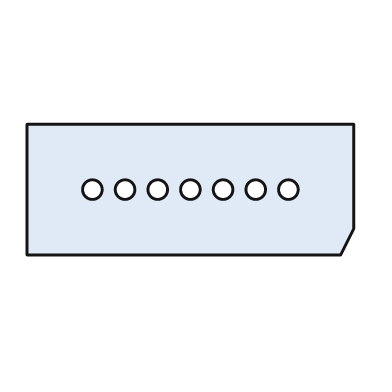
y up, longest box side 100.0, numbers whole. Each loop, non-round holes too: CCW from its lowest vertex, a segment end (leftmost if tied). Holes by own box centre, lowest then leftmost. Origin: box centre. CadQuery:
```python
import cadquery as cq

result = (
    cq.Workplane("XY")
    .moveTo(-50.0, -20.0)
    .lineTo(46.0, -20.0)
    .lineTo(50.0, -12.0)
    .lineTo(50.0, 20.0)
    .lineTo(-50.0, 20.0)
    .close()
    .moveTo(-30.0, 0.0)
    .circle(3.0)
    .moveTo(-20.0, 0.0)
    .circle(3.0)
    .moveTo(-10.0, 0.0)
    .circle(3.0)
    .moveTo(0.0, 0.0)
    .circle(3.0)
    .moveTo(10.0, 0.0)
    .circle(3.0)
    .moveTo(20.0, 0.0)
    .circle(3.0)
    .moveTo(30.0, 0.0)
    .circle(3.0)
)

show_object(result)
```